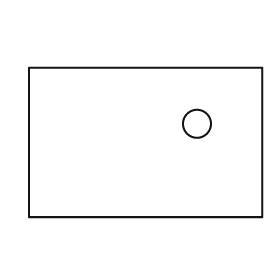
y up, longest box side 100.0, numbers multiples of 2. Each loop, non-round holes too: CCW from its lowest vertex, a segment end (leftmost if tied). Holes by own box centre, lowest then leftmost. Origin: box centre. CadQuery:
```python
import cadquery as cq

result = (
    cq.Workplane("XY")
    .moveTo(-50.0, -32.0)
    .lineTo(50.0, -32.0)
    .lineTo(50.0, 32.0)
    .lineTo(-50.0, 32.0)
    .close()
    .moveTo(22.0, 8.0)
    .circle(6.0)
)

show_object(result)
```